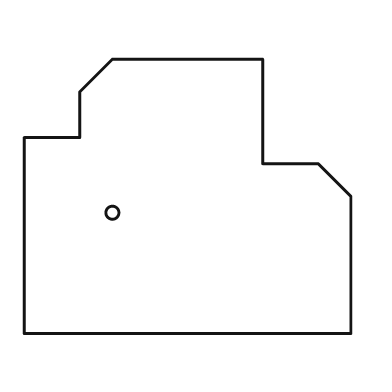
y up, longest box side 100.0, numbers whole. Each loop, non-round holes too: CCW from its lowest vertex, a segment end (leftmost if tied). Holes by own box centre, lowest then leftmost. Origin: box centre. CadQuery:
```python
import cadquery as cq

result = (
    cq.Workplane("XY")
    .moveTo(-50.0, -42.0)
    .lineTo(50.0, -42.0)
    .lineTo(50.0, 0.0)
    .lineTo(40.0, 10.0)
    .lineTo(23.0, 10.0)
    .lineTo(23.0, 42.0)
    .lineTo(-23.0, 42.0)
    .lineTo(-33.0, 32.0)
    .lineTo(-33.0, 18.0)
    .lineTo(-50.0, 18.0)
    .close()
    .moveTo(-23.0, -5.0)
    .circle(2.0)
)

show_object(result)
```